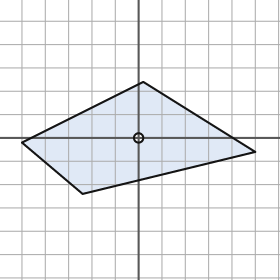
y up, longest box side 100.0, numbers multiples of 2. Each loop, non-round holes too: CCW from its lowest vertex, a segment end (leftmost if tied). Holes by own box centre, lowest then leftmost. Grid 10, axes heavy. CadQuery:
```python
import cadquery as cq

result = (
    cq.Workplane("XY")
    .moveTo(-24.0, -24.0)
    .lineTo(50.0, -6.0)
    .lineTo(2.0, 24.0)
    .lineTo(-50.0, -2.0)
    .close()
    .moveTo(0.0, 0.0)
    .circle(2.0)
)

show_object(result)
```